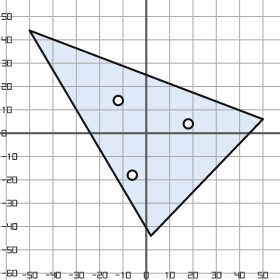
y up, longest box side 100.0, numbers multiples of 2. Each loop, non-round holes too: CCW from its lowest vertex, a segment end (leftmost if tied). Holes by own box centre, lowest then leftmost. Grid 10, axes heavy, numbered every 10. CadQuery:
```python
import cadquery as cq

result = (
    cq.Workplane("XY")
    .moveTo(2.0, -44.0)
    .lineTo(50.0, 6.0)
    .lineTo(-50.0, 44.0)
    .close()
    .moveTo(-6.0, -18.0)
    .circle(2.0)
    .moveTo(18.0, 4.0)
    .circle(2.0)
    .moveTo(-12.0, 14.0)
    .circle(2.0)
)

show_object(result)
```